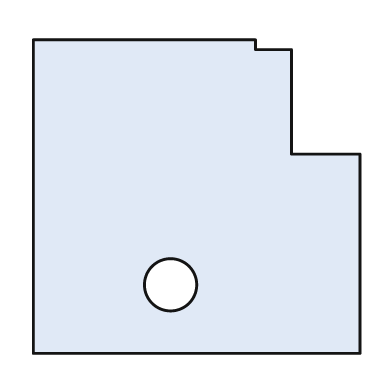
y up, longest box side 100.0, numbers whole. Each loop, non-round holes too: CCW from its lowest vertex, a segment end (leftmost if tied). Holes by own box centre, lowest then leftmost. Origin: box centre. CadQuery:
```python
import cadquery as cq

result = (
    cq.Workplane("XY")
    .moveTo(-50.0, -48.0)
    .lineTo(50.0, -48.0)
    .lineTo(50.0, 13.0)
    .lineTo(29.0, 13.0)
    .lineTo(29.0, 45.0)
    .lineTo(18.0, 45.0)
    .lineTo(18.0, 48.0)
    .lineTo(-50.0, 48.0)
    .close()
    .moveTo(-8.0, -27.0)
    .circle(8.0)
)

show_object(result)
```